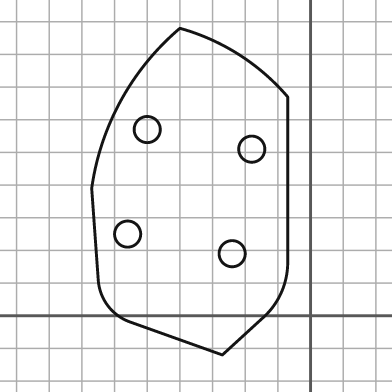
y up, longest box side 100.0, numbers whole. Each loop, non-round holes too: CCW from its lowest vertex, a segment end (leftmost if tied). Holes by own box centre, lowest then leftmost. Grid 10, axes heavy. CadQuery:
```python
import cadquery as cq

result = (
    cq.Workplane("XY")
    .moveTo(-27.0, -12.0)
    .lineTo(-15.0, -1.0)
    .threePointArc((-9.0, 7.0), (-7.0, 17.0))
    .lineTo(-7.0, 67.0)
    .threePointArc((-22.0, 80.0), (-40.0, 88.0))
    .threePointArc((-58.0, 66.0), (-67.0, 39.0))
    .lineTo(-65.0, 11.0)
    .threePointArc((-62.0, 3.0), (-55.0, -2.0))
    .close()
    .moveTo(-24.0, 19.0)
    .circle(4.0)
    .moveTo(-56.0, 25.0)
    .circle(4.0)
    .moveTo(-18.0, 51.0)
    .circle(4.0)
    .moveTo(-50.0, 57.0)
    .circle(4.0)
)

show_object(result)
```